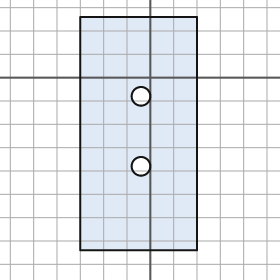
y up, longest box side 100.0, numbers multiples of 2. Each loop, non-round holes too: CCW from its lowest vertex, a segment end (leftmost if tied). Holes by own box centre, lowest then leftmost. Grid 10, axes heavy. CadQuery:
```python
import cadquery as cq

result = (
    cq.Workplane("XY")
    .moveTo(-30.0, -74.0)
    .lineTo(20.0, -74.0)
    .lineTo(20.0, 26.0)
    .lineTo(-30.0, 26.0)
    .close()
    .moveTo(-4.0, -38.0)
    .circle(4.0)
    .moveTo(-4.0, -8.0)
    .circle(4.0)
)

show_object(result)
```